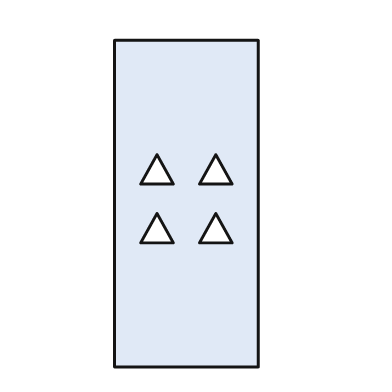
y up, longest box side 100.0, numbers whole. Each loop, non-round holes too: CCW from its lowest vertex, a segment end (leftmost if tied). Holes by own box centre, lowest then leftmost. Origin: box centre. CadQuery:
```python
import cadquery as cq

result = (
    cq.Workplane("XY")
    .moveTo(-22.0, -50.0)
    .lineTo(22.0, -50.0)
    .lineTo(22.0, 50.0)
    .lineTo(-22.0, 50.0)
    .close()
    .moveTo(-14.0, -12.0)
    .lineTo(-4.0, -12.0)
    .lineTo(-9.0, -3.0)
    .close()
    .moveTo(4.0, -12.0)
    .lineTo(14.0, -12.0)
    .lineTo(9.0, -3.0)
    .close()
    .moveTo(-14.0, 6.0)
    .lineTo(-4.0, 6.0)
    .lineTo(-9.0, 15.0)
    .close()
    .moveTo(4.0, 6.0)
    .lineTo(14.0, 6.0)
    .lineTo(9.0, 15.0)
    .close()
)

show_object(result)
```